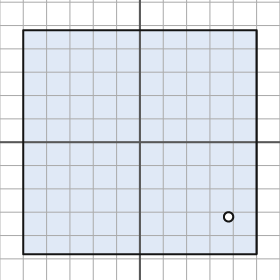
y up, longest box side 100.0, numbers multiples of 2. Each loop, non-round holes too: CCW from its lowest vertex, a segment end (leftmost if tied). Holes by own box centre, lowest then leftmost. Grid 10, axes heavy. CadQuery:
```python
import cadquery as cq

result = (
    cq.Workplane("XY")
    .moveTo(-50.0, -48.0)
    .lineTo(50.0, -48.0)
    .lineTo(50.0, 48.0)
    .lineTo(-50.0, 48.0)
    .close()
    .moveTo(38.0, -32.0)
    .circle(2.0)
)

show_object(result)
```